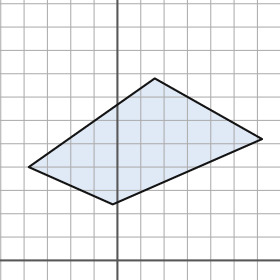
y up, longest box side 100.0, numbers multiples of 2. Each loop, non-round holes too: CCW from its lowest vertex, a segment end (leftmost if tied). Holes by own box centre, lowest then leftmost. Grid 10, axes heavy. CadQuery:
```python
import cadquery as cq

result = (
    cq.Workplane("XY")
    .moveTo(-2.0, 24.0)
    .lineTo(62.0, 52.0)
    .lineTo(16.0, 78.0)
    .lineTo(-38.0, 40.0)
    .close()
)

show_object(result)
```